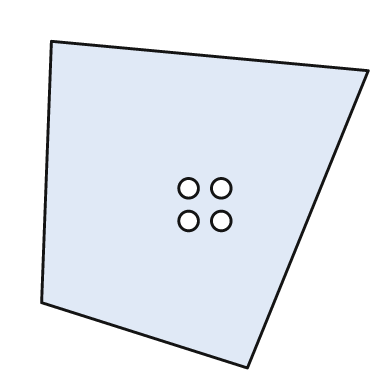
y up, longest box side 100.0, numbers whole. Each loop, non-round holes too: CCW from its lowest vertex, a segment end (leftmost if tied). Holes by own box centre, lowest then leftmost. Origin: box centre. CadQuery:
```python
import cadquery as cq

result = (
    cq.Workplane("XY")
    .moveTo(13.0, -50.0)
    .lineTo(50.0, 41.0)
    .lineTo(-47.0, 50.0)
    .lineTo(-50.0, -30.0)
    .close()
    .moveTo(-5.0, -5.0)
    .circle(3.0)
    .moveTo(5.0, -5.0)
    .circle(3.0)
    .moveTo(-5.0, 5.0)
    .circle(3.0)
    .moveTo(5.0, 5.0)
    .circle(3.0)
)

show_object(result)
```